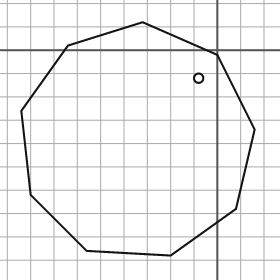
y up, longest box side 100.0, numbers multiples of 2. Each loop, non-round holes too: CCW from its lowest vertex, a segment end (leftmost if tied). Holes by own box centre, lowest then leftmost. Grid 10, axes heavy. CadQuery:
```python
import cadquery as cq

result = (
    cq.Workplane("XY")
    .moveTo(-20.0, -88.0)
    .lineTo(8.0, -68.0)
    .lineTo(16.0, -34.0)
    .lineTo(0.0, -2.0)
    .lineTo(-32.0, 12.0)
    .lineTo(-64.0, 2.0)
    .lineTo(-84.0, -26.0)
    .lineTo(-80.0, -62.0)
    .lineTo(-56.0, -86.0)
    .close()
    .moveTo(-8.0, -12.0)
    .circle(2.0)
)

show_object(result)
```